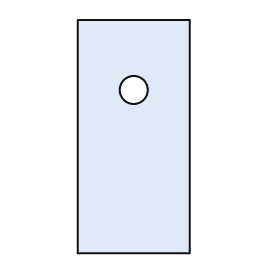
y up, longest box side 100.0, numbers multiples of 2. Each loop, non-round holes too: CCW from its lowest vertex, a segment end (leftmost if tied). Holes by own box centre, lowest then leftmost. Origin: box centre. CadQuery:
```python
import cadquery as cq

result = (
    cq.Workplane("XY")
    .moveTo(-24.0, -50.0)
    .lineTo(24.0, -50.0)
    .lineTo(24.0, 50.0)
    .lineTo(-24.0, 50.0)
    .close()
    .moveTo(0.0, 20.0)
    .circle(6.0)
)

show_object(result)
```